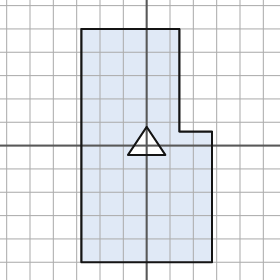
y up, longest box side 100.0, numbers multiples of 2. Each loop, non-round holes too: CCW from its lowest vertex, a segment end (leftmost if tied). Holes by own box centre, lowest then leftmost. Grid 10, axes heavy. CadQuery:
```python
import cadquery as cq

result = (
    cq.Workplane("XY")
    .moveTo(-28.0, -50.0)
    .lineTo(28.0, -50.0)
    .lineTo(28.0, 6.0)
    .lineTo(14.0, 6.0)
    .lineTo(14.0, 50.0)
    .lineTo(-28.0, 50.0)
    .close()
    .moveTo(-8.0, -4.0)
    .lineTo(8.0, -4.0)
    .lineTo(0.0, 8.0)
    .close()
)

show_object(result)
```